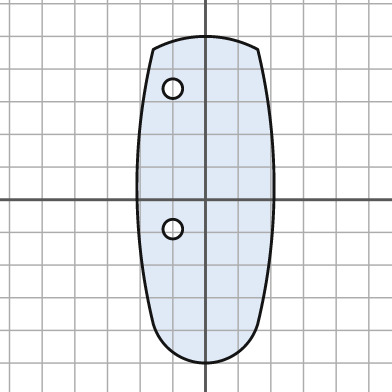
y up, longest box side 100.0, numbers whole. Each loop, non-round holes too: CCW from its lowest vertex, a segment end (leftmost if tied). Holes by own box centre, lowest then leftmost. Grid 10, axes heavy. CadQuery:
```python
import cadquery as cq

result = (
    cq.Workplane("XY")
    .moveTo(-16.0, -38.0)
    .threePointArc((0.0, -50.0), (16.0, -38.0))
    .threePointArc((21.0, 4.0), (16.0, 46.0))
    .threePointArc((0.0, 50.0), (-16.0, 46.0))
    .threePointArc((-21.0, 4.0), (-16.0, -38.0))
    .close()
    .moveTo(-10.0, -9.0)
    .circle(3.0)
    .moveTo(-10.0, 34.0)
    .circle(3.0)
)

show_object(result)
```